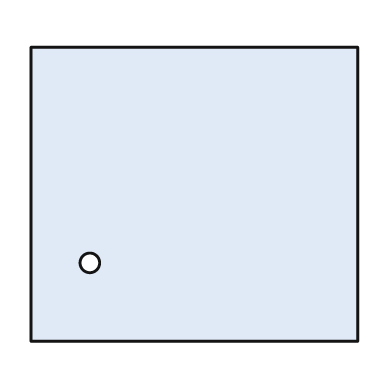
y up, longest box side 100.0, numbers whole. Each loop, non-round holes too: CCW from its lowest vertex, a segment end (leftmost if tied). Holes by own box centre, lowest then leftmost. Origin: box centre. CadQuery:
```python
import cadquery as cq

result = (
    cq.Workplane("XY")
    .moveTo(-50.0, -45.0)
    .lineTo(50.0, -45.0)
    .lineTo(50.0, 45.0)
    .lineTo(-50.0, 45.0)
    .close()
    .moveTo(-32.0, -21.0)
    .circle(3.0)
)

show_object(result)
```